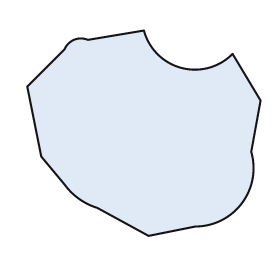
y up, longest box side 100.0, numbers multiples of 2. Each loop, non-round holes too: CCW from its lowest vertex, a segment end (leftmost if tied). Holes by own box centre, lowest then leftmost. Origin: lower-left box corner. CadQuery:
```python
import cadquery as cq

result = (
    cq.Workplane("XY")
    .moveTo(52.0, 0.0)
    .lineTo(72.0, 4.0)
    .threePointArc((92.0, 14.0), (96.0, 36.0))
    .lineTo(100.0, 58.0)
    .lineTo(88.0, 78.0)
    .threePointArc((66.0, 72.0), (50.0, 88.0))
    .lineTo(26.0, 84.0)
    .threePointArc((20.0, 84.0), (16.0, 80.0))
    .lineTo(0.0, 64.0)
    .lineTo(6.0, 34.0)
    .lineTo(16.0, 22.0)
    .threePointArc((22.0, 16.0), (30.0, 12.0))
    .close()
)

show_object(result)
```